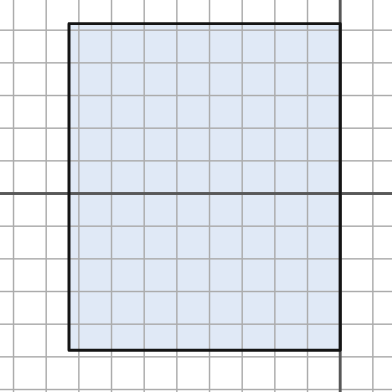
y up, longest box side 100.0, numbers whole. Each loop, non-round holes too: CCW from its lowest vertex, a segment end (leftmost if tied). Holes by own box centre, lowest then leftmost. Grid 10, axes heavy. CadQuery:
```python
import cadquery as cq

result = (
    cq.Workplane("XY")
    .moveTo(-83.0, -48.0)
    .lineTo(0.0, -48.0)
    .lineTo(0.0, 52.0)
    .lineTo(-83.0, 52.0)
    .close()
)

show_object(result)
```